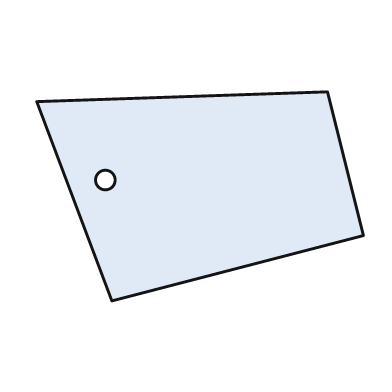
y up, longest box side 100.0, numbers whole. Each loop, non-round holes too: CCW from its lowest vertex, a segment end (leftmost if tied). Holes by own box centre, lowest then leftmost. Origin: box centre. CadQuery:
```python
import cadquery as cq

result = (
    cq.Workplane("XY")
    .moveTo(-27.0, -32.0)
    .lineTo(50.0, -12.0)
    .lineTo(39.0, 32.0)
    .lineTo(-50.0, 29.0)
    .close()
    .moveTo(-29.0, 5.0)
    .circle(3.0)
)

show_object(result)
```